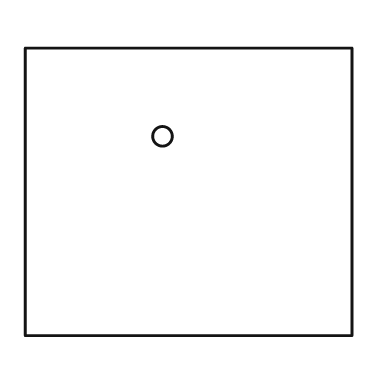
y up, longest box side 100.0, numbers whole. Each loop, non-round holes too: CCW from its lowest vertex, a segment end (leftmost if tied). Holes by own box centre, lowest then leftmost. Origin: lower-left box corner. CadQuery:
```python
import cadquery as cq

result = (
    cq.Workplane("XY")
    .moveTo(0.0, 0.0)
    .lineTo(100.0, 0.0)
    .lineTo(100.0, 88.0)
    .lineTo(0.0, 88.0)
    .close()
    .moveTo(42.0, 61.0)
    .circle(3.0)
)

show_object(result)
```